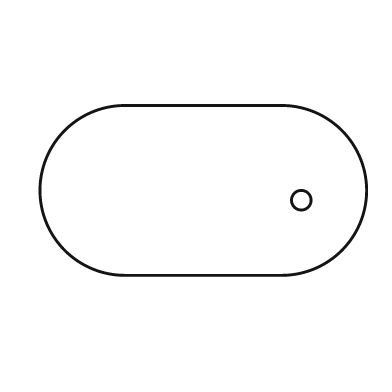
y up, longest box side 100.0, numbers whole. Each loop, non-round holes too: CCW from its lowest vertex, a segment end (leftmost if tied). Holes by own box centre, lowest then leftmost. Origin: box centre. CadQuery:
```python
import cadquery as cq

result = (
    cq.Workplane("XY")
    .moveTo(-24.0, -26.0)
    .lineTo(24.0, -26.0)
    .threePointArc((50.0, 0.0), (24.0, 26.0))
    .lineTo(-24.0, 26.0)
    .threePointArc((-50.0, 0.0), (-24.0, -26.0))
    .close()
    .moveTo(30.0, -3.0)
    .circle(3.0)
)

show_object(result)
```